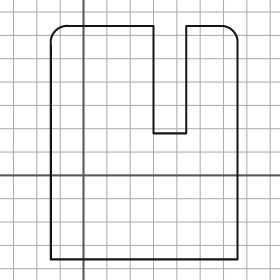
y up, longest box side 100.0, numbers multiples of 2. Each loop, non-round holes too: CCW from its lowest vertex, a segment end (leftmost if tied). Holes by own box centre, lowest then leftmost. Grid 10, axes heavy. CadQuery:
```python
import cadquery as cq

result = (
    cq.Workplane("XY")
    .moveTo(-14.0, -36.0)
    .lineTo(66.0, -36.0)
    .lineTo(66.0, 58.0)
    .threePointArc((64.0, 62.0), (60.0, 64.0))
    .lineTo(44.0, 64.0)
    .lineTo(44.0, 18.0)
    .lineTo(30.0, 18.0)
    .lineTo(30.0, 64.0)
    .lineTo(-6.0, 64.0)
    .threePointArc((-12.0, 62.0), (-14.0, 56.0))
    .close()
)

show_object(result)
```